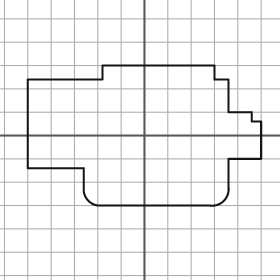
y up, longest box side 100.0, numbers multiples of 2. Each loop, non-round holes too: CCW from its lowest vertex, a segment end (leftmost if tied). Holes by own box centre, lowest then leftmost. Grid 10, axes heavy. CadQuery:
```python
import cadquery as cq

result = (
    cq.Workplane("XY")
    .moveTo(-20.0, -30.0)
    .lineTo(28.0, -30.0)
    .threePointArc((34.0, -28.0), (36.0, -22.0))
    .lineTo(36.0, -10.0)
    .lineTo(50.0, -10.0)
    .lineTo(50.0, 6.0)
    .lineTo(46.0, 6.0)
    .lineTo(46.0, 10.0)
    .lineTo(36.0, 10.0)
    .lineTo(36.0, 24.0)
    .lineTo(30.0, 24.0)
    .lineTo(30.0, 30.0)
    .lineTo(-18.0, 30.0)
    .lineTo(-18.0, 24.0)
    .lineTo(-50.0, 24.0)
    .lineTo(-50.0, -14.0)
    .lineTo(-26.0, -14.0)
    .lineTo(-26.0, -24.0)
    .threePointArc((-24.0, -28.0), (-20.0, -30.0))
    .close()
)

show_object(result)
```